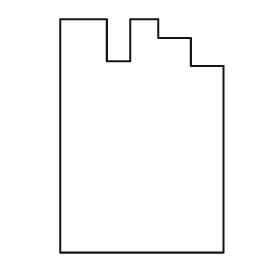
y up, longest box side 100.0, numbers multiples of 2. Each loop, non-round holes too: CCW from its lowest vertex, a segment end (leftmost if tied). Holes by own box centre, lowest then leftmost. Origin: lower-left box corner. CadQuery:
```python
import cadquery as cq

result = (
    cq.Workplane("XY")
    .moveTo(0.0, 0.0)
    .lineTo(70.0, 0.0)
    .lineTo(70.0, 80.0)
    .lineTo(56.0, 80.0)
    .lineTo(56.0, 92.0)
    .lineTo(42.0, 92.0)
    .lineTo(42.0, 100.0)
    .lineTo(30.0, 100.0)
    .lineTo(30.0, 82.0)
    .lineTo(20.0, 82.0)
    .lineTo(20.0, 100.0)
    .lineTo(0.0, 100.0)
    .close()
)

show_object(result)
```